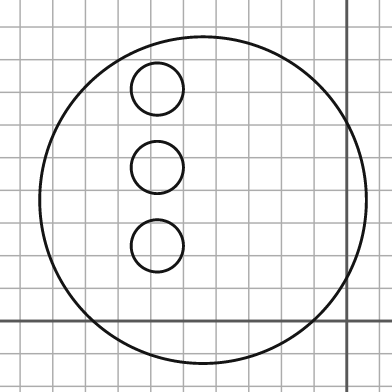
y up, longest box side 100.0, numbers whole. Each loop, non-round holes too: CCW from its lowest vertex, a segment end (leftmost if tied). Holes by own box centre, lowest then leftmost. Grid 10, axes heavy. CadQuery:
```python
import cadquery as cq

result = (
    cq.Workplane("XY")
    .moveTo(-44.0, 37.0)
    .circle(50.0)
    .moveTo(-58.0, 23.0)
    .circle(8.0)
    .moveTo(-58.0, 47.0)
    .circle(8.0)
    .moveTo(-58.0, 71.0)
    .circle(8.0)
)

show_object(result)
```